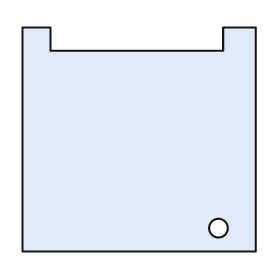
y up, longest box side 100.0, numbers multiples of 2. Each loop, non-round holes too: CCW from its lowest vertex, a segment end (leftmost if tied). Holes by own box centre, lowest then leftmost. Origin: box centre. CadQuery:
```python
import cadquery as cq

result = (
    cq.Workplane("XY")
    .moveTo(-50.0, -48.0)
    .lineTo(50.0, -48.0)
    .lineTo(50.0, 48.0)
    .lineTo(36.0, 48.0)
    .lineTo(36.0, 38.0)
    .lineTo(-38.0, 38.0)
    .lineTo(-38.0, 48.0)
    .lineTo(-50.0, 48.0)
    .close()
    .moveTo(34.0, -38.0)
    .circle(4.0)
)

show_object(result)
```